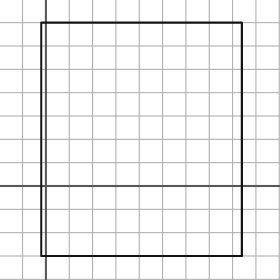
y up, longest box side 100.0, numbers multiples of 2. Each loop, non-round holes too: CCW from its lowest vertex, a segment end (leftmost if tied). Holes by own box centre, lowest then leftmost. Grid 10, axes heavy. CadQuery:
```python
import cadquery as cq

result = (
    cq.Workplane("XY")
    .moveTo(-2.0, -30.0)
    .lineTo(84.0, -30.0)
    .lineTo(84.0, 70.0)
    .lineTo(-2.0, 70.0)
    .close()
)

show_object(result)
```